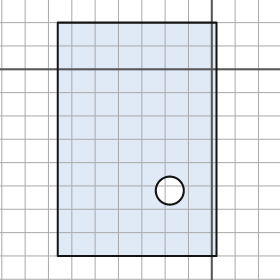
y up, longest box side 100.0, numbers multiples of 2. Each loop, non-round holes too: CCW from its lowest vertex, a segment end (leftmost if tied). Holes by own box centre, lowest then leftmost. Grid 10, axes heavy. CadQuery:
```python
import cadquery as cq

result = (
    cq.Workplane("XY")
    .moveTo(-66.0, -80.0)
    .lineTo(2.0, -80.0)
    .lineTo(2.0, 20.0)
    .lineTo(-66.0, 20.0)
    .close()
    .moveTo(-18.0, -52.0)
    .circle(6.0)
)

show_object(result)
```